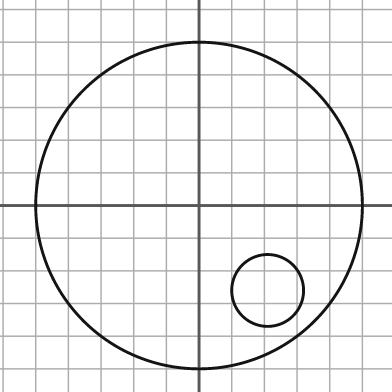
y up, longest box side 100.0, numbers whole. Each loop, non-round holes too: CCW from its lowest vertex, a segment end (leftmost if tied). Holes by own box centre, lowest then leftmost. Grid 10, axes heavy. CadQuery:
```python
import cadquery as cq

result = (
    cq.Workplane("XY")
    .moveTo(0.0, 0.0)
    .circle(50.0)
    .moveTo(21.0, -26.0)
    .circle(11.0)
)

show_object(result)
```